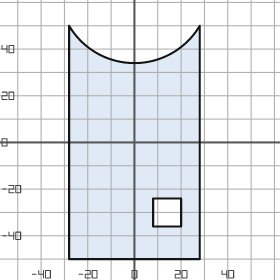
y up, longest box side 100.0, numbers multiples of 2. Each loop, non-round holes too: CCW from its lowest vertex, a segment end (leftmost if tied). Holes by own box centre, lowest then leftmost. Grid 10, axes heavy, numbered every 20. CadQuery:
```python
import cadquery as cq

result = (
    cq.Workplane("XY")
    .moveTo(-28.0, -50.0)
    .lineTo(28.0, -50.0)
    .lineTo(28.0, 50.0)
    .threePointArc((0.0, 34.0), (-28.0, 50.0))
    .close()
    .moveTo(8.0, -36.0)
    .lineTo(20.0, -36.0)
    .lineTo(20.0, -24.0)
    .lineTo(8.0, -24.0)
    .close()
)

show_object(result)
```